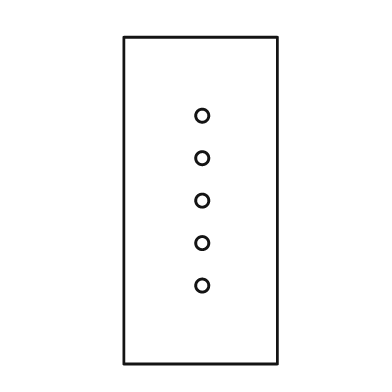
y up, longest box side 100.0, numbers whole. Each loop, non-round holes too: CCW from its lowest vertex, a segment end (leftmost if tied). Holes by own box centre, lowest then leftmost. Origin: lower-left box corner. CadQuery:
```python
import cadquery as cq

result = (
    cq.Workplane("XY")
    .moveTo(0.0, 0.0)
    .lineTo(47.0, 0.0)
    .lineTo(47.0, 100.0)
    .lineTo(0.0, 100.0)
    .close()
    .moveTo(24.0, 24.0)
    .circle(2.0)
    .moveTo(24.0, 37.0)
    .circle(2.0)
    .moveTo(24.0, 50.0)
    .circle(2.0)
    .moveTo(24.0, 63.0)
    .circle(2.0)
    .moveTo(24.0, 76.0)
    .circle(2.0)
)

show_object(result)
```